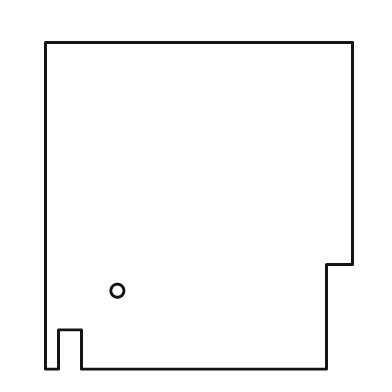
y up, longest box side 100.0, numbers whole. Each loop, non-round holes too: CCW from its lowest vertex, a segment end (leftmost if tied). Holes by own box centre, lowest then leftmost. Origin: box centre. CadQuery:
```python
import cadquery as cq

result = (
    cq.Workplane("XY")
    .moveTo(-47.0, -50.0)
    .lineTo(-43.0, -50.0)
    .lineTo(-43.0, -38.0)
    .lineTo(-36.0, -38.0)
    .lineTo(-36.0, -50.0)
    .lineTo(39.0, -50.0)
    .lineTo(39.0, -18.0)
    .lineTo(47.0, -18.0)
    .lineTo(47.0, 50.0)
    .lineTo(-47.0, 50.0)
    .close()
    .moveTo(-25.0, -26.0)
    .circle(2.0)
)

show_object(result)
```